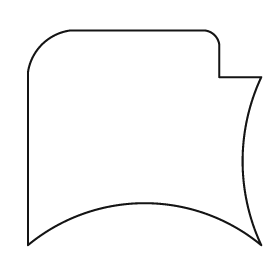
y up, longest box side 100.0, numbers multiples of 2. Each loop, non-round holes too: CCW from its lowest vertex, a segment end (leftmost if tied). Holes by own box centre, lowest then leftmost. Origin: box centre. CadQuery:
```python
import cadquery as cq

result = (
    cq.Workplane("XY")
    .moveTo(-50.0, -46.0)
    .threePointArc((0.0, -28.0), (50.0, -46.0))
    .threePointArc((42.0, -10.0), (50.0, 26.0))
    .lineTo(32.0, 26.0)
    .lineTo(32.0, 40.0)
    .threePointArc((30.0, 44.0), (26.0, 46.0))
    .lineTo(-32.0, 46.0)
    .threePointArc((-44.0, 40.0), (-50.0, 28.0))
    .close()
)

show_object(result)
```